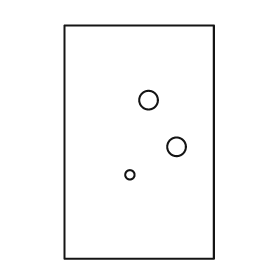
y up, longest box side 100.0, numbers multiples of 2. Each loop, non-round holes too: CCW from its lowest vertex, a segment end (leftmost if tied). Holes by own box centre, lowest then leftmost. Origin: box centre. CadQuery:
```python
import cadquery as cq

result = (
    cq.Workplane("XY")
    .moveTo(-32.0, -50.0)
    .lineTo(32.0, -50.0)
    .lineTo(32.0, 50.0)
    .lineTo(-32.0, 50.0)
    .close()
    .moveTo(-4.0, -14.0)
    .circle(2.0)
    .moveTo(16.0, -2.0)
    .circle(4.0)
    .moveTo(4.0, 18.0)
    .circle(4.0)
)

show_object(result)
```